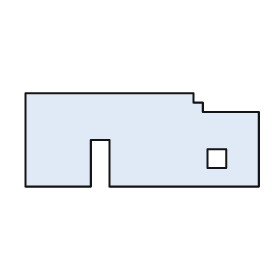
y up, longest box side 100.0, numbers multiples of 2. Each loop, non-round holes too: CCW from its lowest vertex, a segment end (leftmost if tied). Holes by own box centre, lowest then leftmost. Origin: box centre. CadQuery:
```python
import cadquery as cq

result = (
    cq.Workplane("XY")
    .moveTo(-50.0, -20.0)
    .lineTo(-22.0, -20.0)
    .lineTo(-22.0, 0.0)
    .lineTo(-14.0, 0.0)
    .lineTo(-14.0, -20.0)
    .lineTo(50.0, -20.0)
    .lineTo(50.0, 12.0)
    .lineTo(26.0, 12.0)
    .lineTo(26.0, 16.0)
    .lineTo(22.0, 16.0)
    .lineTo(22.0, 20.0)
    .lineTo(-50.0, 20.0)
    .close()
    .moveTo(28.0, -12.0)
    .lineTo(36.0, -12.0)
    .lineTo(36.0, -4.0)
    .lineTo(28.0, -4.0)
    .close()
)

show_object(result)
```